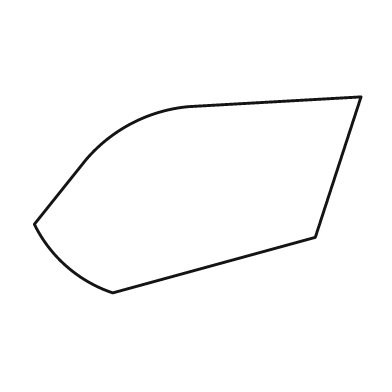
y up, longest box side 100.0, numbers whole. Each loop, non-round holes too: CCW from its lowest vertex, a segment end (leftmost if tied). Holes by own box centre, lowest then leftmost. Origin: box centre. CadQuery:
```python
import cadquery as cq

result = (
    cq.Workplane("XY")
    .moveTo(-26.0, -30.0)
    .lineTo(36.0, -13.0)
    .lineTo(50.0, 30.0)
    .lineTo(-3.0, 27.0)
    .threePointArc((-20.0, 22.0), (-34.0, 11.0))
    .lineTo(-50.0, -9.0)
    .threePointArc((-40.0, -22.0), (-26.0, -30.0))
    .close()
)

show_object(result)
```